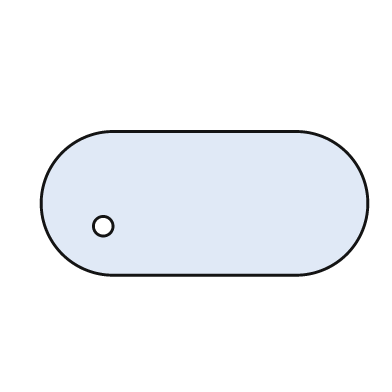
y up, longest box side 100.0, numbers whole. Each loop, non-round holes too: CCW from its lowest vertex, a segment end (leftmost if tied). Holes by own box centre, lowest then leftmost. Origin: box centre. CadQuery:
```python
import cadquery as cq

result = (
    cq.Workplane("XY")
    .moveTo(-28.0, -22.0)
    .lineTo(28.0, -22.0)
    .threePointArc((50.0, 0.0), (28.0, 22.0))
    .lineTo(-28.0, 22.0)
    .threePointArc((-50.0, 0.0), (-28.0, -22.0))
    .close()
    .moveTo(-31.0, -7.0)
    .circle(3.0)
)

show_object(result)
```